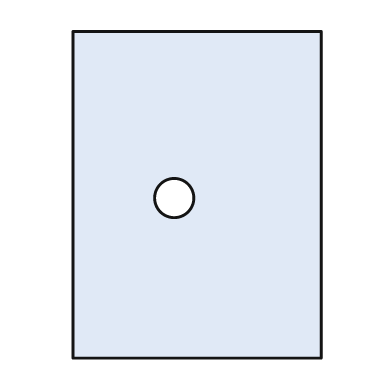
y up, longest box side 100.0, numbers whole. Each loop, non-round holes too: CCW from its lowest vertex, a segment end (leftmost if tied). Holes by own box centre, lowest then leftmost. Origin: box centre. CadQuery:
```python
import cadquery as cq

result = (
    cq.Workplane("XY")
    .moveTo(-38.0, -50.0)
    .lineTo(38.0, -50.0)
    .lineTo(38.0, 50.0)
    .lineTo(-38.0, 50.0)
    .close()
    .moveTo(-7.0, -1.0)
    .circle(6.0)
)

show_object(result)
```